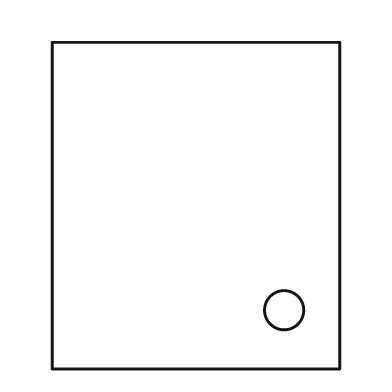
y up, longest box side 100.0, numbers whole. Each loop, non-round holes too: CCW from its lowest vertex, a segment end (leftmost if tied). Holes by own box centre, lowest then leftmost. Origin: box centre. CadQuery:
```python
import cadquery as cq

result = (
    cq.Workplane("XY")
    .moveTo(-44.0, -50.0)
    .lineTo(44.0, -50.0)
    .lineTo(44.0, 50.0)
    .lineTo(-44.0, 50.0)
    .close()
    .moveTo(27.0, -32.0)
    .circle(6.0)
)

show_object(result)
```